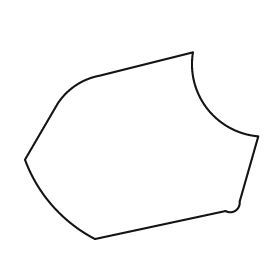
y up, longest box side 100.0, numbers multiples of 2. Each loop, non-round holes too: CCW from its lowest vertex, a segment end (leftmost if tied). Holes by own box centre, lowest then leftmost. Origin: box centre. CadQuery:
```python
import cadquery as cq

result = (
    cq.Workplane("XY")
    .moveTo(-20.0, -40.0)
    .lineTo(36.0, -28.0)
    .threePointArc((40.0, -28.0), (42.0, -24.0))
    .lineTo(50.0, 4.0)
    .threePointArc((28.0, 16.0), (22.0, 40.0))
    .lineTo(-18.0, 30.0)
    .threePointArc((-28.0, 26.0), (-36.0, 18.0))
    .lineTo(-50.0, -6.0)
    .threePointArc((-38.0, -26.0), (-20.0, -40.0))
    .close()
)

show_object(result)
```